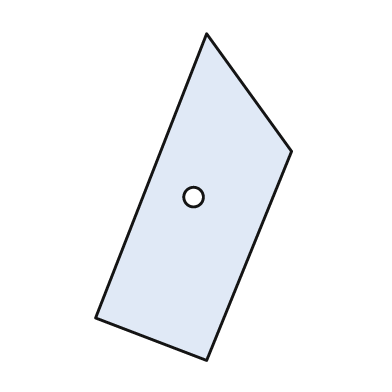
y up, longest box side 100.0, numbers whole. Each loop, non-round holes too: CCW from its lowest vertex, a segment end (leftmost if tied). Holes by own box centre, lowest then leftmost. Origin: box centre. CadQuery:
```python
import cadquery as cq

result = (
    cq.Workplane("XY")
    .moveTo(4.0, -50.0)
    .lineTo(30.0, 14.0)
    .lineTo(4.0, 50.0)
    .lineTo(-30.0, -37.0)
    .close()
    .moveTo(0.0, 0.0)
    .circle(3.0)
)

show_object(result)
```